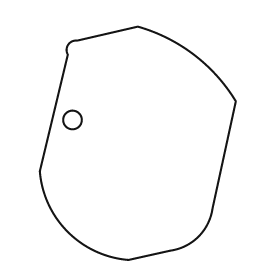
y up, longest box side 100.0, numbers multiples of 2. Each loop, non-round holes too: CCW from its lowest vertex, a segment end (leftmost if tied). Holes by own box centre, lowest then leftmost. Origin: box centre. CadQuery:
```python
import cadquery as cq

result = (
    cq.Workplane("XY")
    .moveTo(-4.0, -50.0)
    .lineTo(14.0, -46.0)
    .threePointArc((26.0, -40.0), (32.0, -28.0))
    .lineTo(42.0, 18.0)
    .threePointArc((24.0, 38.0), (0.0, 50.0))
    .lineTo(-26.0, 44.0)
    .threePointArc((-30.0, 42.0), (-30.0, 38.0))
    .lineTo(-42.0, -12.0)
    .threePointArc((-30.0, -38.0), (-4.0, -50.0))
    .close()
    .moveTo(-28.0, 10.0)
    .circle(4.0)
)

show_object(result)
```